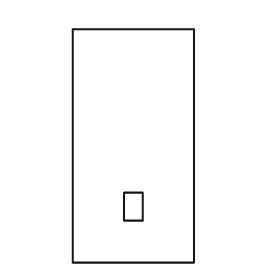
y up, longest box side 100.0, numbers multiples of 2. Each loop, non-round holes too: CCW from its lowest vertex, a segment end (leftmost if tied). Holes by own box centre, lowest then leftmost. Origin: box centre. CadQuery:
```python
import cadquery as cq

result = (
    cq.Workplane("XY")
    .moveTo(-26.0, -50.0)
    .lineTo(26.0, -50.0)
    .lineTo(26.0, 50.0)
    .lineTo(-26.0, 50.0)
    .close()
    .moveTo(-4.0, -32.0)
    .lineTo(4.0, -32.0)
    .lineTo(4.0, -20.0)
    .lineTo(-4.0, -20.0)
    .close()
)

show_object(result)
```